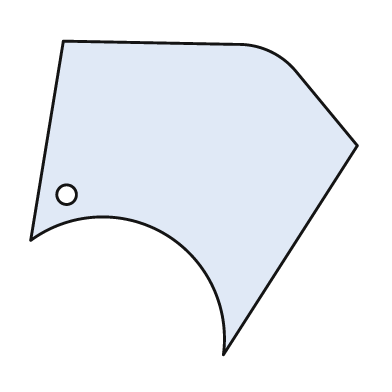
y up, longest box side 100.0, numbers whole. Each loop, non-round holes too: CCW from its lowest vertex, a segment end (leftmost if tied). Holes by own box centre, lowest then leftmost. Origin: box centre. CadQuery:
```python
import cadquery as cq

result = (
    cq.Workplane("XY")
    .moveTo(9.0, -48.0)
    .lineTo(50.0, 16.0)
    .lineTo(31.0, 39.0)
    .threePointArc((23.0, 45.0), (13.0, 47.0))
    .lineTo(-40.0, 48.0)
    .lineTo(-50.0, -13.0)
    .threePointArc((-9.0, -11.0), (9.0, -48.0))
    .close()
    .moveTo(-39.0, 1.0)
    .circle(3.0)
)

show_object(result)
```